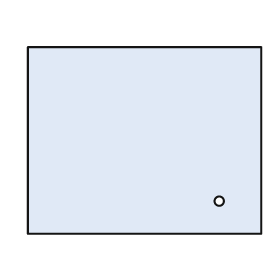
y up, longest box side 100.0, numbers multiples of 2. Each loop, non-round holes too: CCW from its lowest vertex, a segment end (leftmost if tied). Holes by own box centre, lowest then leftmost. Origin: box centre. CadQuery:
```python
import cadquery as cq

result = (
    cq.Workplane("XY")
    .moveTo(-50.0, -40.0)
    .lineTo(50.0, -40.0)
    .lineTo(50.0, 40.0)
    .lineTo(-50.0, 40.0)
    .close()
    .moveTo(32.0, -26.0)
    .circle(2.0)
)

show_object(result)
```